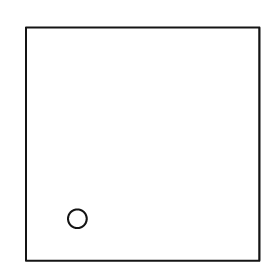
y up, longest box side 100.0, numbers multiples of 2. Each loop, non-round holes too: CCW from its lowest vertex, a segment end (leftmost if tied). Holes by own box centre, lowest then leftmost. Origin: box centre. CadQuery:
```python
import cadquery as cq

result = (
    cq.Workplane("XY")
    .moveTo(-50.0, -50.0)
    .lineTo(50.0, -50.0)
    .lineTo(50.0, 50.0)
    .lineTo(-50.0, 50.0)
    .close()
    .moveTo(-28.0, -32.0)
    .circle(4.0)
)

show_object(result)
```